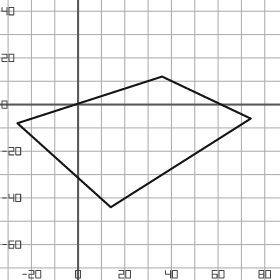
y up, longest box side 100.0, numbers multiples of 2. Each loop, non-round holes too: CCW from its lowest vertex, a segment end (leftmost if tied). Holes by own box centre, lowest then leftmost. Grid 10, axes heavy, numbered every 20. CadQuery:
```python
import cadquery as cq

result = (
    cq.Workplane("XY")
    .moveTo(14.0, -44.0)
    .lineTo(74.0, -6.0)
    .lineTo(36.0, 12.0)
    .lineTo(-26.0, -8.0)
    .close()
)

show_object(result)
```